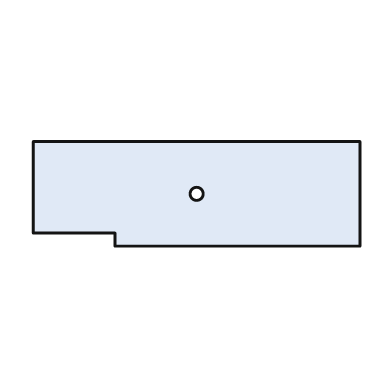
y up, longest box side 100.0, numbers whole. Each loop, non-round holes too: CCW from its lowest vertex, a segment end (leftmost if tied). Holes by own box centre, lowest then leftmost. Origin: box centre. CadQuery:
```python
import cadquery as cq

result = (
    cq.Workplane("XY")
    .moveTo(-25.0, -16.0)
    .lineTo(50.0, -16.0)
    .lineTo(50.0, 16.0)
    .lineTo(-50.0, 16.0)
    .lineTo(-50.0, -12.0)
    .lineTo(-25.0, -12.0)
    .close()
    .moveTo(0.0, 0.0)
    .circle(2.0)
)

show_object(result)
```